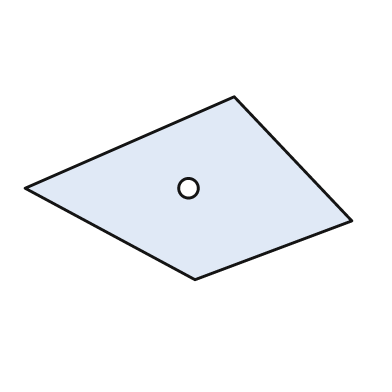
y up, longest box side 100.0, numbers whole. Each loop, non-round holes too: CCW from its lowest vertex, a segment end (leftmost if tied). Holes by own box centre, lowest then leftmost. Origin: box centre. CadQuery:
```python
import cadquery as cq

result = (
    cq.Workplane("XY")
    .moveTo(2.0, -28.0)
    .lineTo(50.0, -10.0)
    .lineTo(14.0, 28.0)
    .lineTo(-50.0, 0.0)
    .close()
    .moveTo(0.0, 0.0)
    .circle(3.0)
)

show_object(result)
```